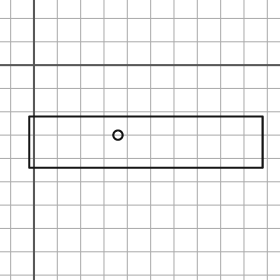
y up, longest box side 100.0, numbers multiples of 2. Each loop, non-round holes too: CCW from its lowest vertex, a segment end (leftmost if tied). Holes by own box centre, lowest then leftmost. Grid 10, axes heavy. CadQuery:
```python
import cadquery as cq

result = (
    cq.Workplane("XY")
    .moveTo(-2.0, -44.0)
    .lineTo(98.0, -44.0)
    .lineTo(98.0, -22.0)
    .lineTo(-2.0, -22.0)
    .close()
    .moveTo(36.0, -30.0)
    .circle(2.0)
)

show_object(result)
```